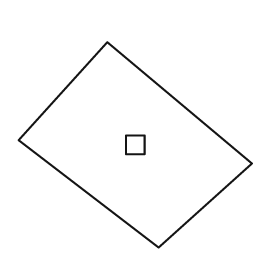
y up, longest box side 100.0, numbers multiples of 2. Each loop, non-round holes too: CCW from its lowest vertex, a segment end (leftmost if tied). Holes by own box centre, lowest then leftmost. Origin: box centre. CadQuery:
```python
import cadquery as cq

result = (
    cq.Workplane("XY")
    .moveTo(10.0, -44.0)
    .lineTo(50.0, -8.0)
    .lineTo(-12.0, 44.0)
    .lineTo(-50.0, 2.0)
    .close()
    .moveTo(-4.0, -4.0)
    .lineTo(4.0, -4.0)
    .lineTo(4.0, 4.0)
    .lineTo(-4.0, 4.0)
    .close()
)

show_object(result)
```